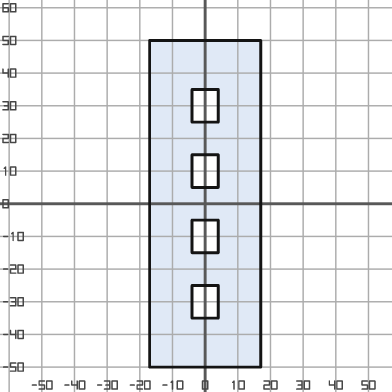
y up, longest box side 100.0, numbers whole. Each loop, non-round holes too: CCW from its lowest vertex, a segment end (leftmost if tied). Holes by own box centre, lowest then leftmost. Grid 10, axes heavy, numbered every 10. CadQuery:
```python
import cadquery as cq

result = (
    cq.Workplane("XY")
    .moveTo(-17.0, -50.0)
    .lineTo(17.0, -50.0)
    .lineTo(17.0, 50.0)
    .lineTo(-17.0, 50.0)
    .close()
    .moveTo(-4.0, -35.0)
    .lineTo(4.0, -35.0)
    .lineTo(4.0, -25.0)
    .lineTo(-4.0, -25.0)
    .close()
    .moveTo(-4.0, -15.0)
    .lineTo(4.0, -15.0)
    .lineTo(4.0, -5.0)
    .lineTo(-4.0, -5.0)
    .close()
    .moveTo(-4.0, 5.0)
    .lineTo(4.0, 5.0)
    .lineTo(4.0, 15.0)
    .lineTo(-4.0, 15.0)
    .close()
    .moveTo(-4.0, 25.0)
    .lineTo(4.0, 25.0)
    .lineTo(4.0, 35.0)
    .lineTo(-4.0, 35.0)
    .close()
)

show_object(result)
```